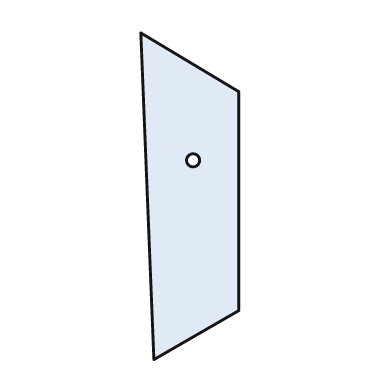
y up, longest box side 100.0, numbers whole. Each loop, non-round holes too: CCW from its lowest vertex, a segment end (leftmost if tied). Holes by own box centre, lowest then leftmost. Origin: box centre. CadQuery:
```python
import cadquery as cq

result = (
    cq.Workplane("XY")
    .moveTo(-11.0, -50.0)
    .lineTo(15.0, -35.0)
    .lineTo(15.0, 32.0)
    .lineTo(-15.0, 50.0)
    .close()
    .moveTo(1.0, 11.0)
    .circle(2.0)
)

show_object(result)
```